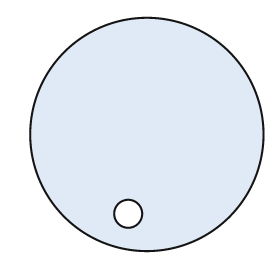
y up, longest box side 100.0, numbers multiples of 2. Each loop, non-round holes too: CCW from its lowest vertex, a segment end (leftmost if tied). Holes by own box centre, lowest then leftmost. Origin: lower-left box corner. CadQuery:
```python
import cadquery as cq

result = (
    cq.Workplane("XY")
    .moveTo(50.0, 50.0)
    .circle(50.0)
    .moveTo(42.0, 16.0)
    .circle(6.0)
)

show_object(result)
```